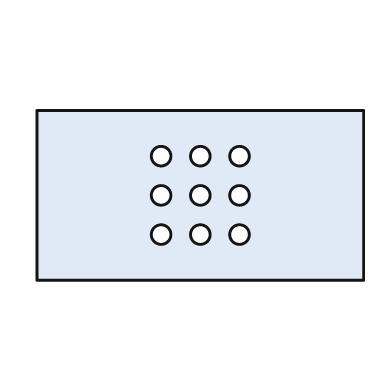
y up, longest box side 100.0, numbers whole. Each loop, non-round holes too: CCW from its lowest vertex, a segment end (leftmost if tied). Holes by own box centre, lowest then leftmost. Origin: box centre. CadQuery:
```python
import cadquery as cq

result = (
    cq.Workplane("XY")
    .moveTo(-50.0, -26.0)
    .lineTo(50.0, -26.0)
    .lineTo(50.0, 26.0)
    .lineTo(-50.0, 26.0)
    .close()
    .moveTo(-12.0, -12.0)
    .circle(3.0)
    .moveTo(0.0, -12.0)
    .circle(3.0)
    .moveTo(12.0, -12.0)
    .circle(3.0)
    .moveTo(-12.0, 0.0)
    .circle(3.0)
    .moveTo(0.0, 0.0)
    .circle(3.0)
    .moveTo(12.0, 0.0)
    .circle(3.0)
    .moveTo(-12.0, 12.0)
    .circle(3.0)
    .moveTo(0.0, 12.0)
    .circle(3.0)
    .moveTo(12.0, 12.0)
    .circle(3.0)
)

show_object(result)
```